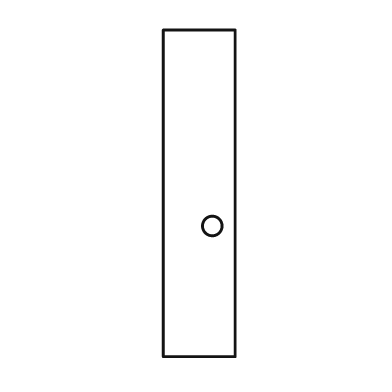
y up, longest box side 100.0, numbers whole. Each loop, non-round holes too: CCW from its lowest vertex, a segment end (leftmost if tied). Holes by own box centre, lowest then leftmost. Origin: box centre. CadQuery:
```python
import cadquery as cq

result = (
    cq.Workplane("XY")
    .moveTo(-11.0, -50.0)
    .lineTo(11.0, -50.0)
    .lineTo(11.0, 50.0)
    .lineTo(-11.0, 50.0)
    .close()
    .moveTo(4.0, -10.0)
    .circle(3.0)
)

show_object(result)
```